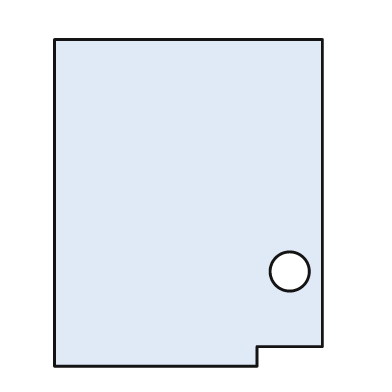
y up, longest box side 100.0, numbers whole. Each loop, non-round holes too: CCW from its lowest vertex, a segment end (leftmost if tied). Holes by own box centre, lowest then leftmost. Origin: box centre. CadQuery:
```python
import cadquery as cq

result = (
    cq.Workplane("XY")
    .moveTo(-41.0, -50.0)
    .lineTo(21.0, -50.0)
    .lineTo(21.0, -44.0)
    .lineTo(41.0, -44.0)
    .lineTo(41.0, 50.0)
    .lineTo(-41.0, 50.0)
    .close()
    .moveTo(31.0, -21.0)
    .circle(6.0)
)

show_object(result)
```